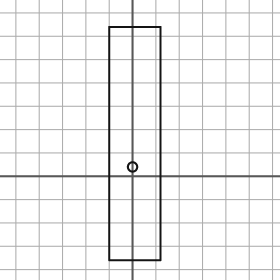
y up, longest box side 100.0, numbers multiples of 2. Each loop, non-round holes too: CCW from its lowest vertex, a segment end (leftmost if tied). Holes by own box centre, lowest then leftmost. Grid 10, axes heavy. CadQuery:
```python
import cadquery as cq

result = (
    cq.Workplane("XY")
    .moveTo(-10.0, -36.0)
    .lineTo(12.0, -36.0)
    .lineTo(12.0, 64.0)
    .lineTo(-10.0, 64.0)
    .close()
    .moveTo(0.0, 4.0)
    .circle(2.0)
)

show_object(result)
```